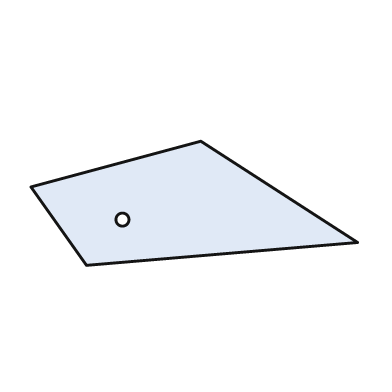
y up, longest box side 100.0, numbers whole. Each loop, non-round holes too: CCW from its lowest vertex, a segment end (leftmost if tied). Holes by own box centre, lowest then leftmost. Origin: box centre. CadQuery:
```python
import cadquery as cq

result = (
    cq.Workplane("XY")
    .moveTo(-33.0, -19.0)
    .lineTo(50.0, -12.0)
    .lineTo(2.0, 19.0)
    .lineTo(-50.0, 5.0)
    .close()
    .moveTo(-22.0, -5.0)
    .circle(2.0)
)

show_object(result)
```